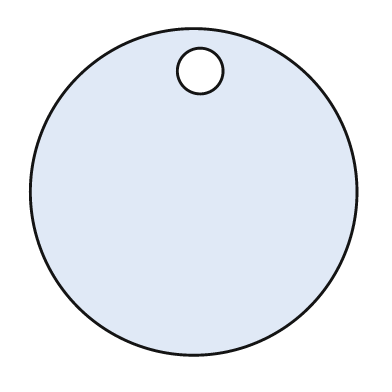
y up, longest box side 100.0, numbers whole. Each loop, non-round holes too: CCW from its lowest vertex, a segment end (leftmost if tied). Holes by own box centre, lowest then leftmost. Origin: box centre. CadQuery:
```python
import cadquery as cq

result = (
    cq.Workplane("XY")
    .moveTo(0.0, 0.0)
    .circle(50.0)
    .moveTo(2.0, 37.0)
    .circle(7.0)
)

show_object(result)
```